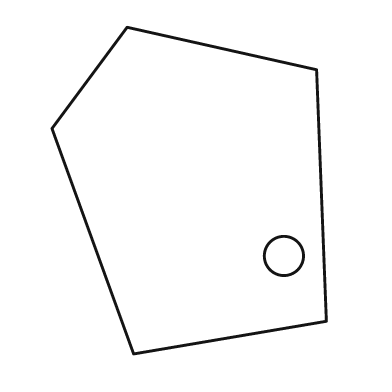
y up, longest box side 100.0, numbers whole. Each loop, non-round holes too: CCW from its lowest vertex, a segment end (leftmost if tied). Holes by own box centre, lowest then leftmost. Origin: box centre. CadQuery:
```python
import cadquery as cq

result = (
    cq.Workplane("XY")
    .moveTo(-17.0, -50.0)
    .lineTo(42.0, -40.0)
    .lineTo(39.0, 37.0)
    .lineTo(-19.0, 50.0)
    .lineTo(-42.0, 19.0)
    .close()
    .moveTo(29.0, -20.0)
    .circle(6.0)
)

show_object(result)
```